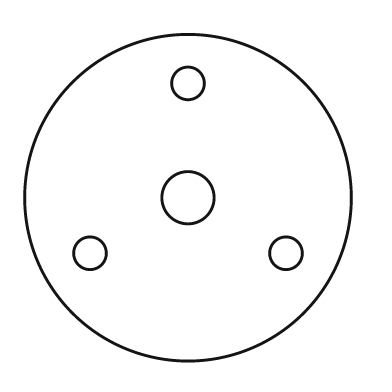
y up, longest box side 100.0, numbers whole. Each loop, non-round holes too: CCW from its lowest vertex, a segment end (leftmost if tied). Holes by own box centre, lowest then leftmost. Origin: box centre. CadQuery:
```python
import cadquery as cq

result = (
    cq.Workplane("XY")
    .moveTo(0.0, 0.0)
    .circle(50.0)
    .moveTo(-30.0, -17.0)
    .circle(5.0)
    .moveTo(30.0, -17.0)
    .circle(5.0)
    .moveTo(0.0, 0.0)
    .circle(8.0)
    .moveTo(0.0, 35.0)
    .circle(5.0)
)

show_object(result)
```